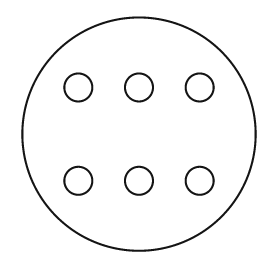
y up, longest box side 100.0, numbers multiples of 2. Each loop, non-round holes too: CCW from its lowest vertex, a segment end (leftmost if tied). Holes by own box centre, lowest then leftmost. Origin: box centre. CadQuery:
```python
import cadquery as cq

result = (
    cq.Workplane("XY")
    .moveTo(0.0, 0.0)
    .circle(50.0)
    .moveTo(-26.0, -20.0)
    .circle(6.0)
    .moveTo(0.0, -20.0)
    .circle(6.0)
    .moveTo(26.0, -20.0)
    .circle(6.0)
    .moveTo(-26.0, 20.0)
    .circle(6.0)
    .moveTo(0.0, 20.0)
    .circle(6.0)
    .moveTo(26.0, 20.0)
    .circle(6.0)
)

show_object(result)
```